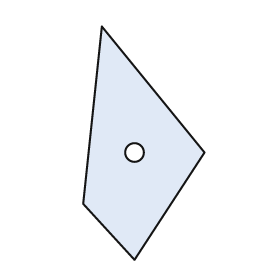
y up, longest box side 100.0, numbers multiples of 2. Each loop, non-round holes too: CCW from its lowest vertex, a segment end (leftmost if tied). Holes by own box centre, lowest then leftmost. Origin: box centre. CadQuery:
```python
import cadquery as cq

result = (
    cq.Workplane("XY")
    .moveTo(-4.0, -50.0)
    .lineTo(26.0, -4.0)
    .lineTo(-18.0, 50.0)
    .lineTo(-26.0, -26.0)
    .close()
    .moveTo(-4.0, -4.0)
    .circle(4.0)
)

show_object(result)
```